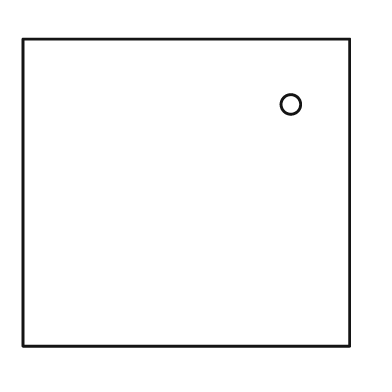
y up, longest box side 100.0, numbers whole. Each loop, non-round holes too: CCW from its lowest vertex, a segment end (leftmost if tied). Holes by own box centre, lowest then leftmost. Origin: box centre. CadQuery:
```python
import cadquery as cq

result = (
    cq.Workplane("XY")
    .moveTo(-50.0, -47.0)
    .lineTo(50.0, -47.0)
    .lineTo(50.0, 47.0)
    .lineTo(-50.0, 47.0)
    .close()
    .moveTo(32.0, 27.0)
    .circle(3.0)
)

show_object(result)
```